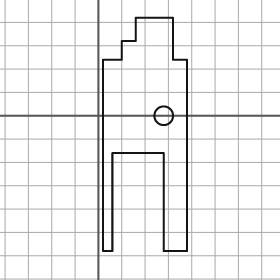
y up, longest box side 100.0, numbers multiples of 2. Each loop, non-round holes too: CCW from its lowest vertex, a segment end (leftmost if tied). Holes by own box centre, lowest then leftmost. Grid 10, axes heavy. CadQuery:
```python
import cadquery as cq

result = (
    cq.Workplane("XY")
    .moveTo(2.0, -58.0)
    .lineTo(6.0, -58.0)
    .lineTo(6.0, -16.0)
    .lineTo(28.0, -16.0)
    .lineTo(28.0, -58.0)
    .lineTo(38.0, -58.0)
    .lineTo(38.0, 24.0)
    .lineTo(32.0, 24.0)
    .lineTo(32.0, 42.0)
    .lineTo(16.0, 42.0)
    .lineTo(16.0, 32.0)
    .lineTo(10.0, 32.0)
    .lineTo(10.0, 24.0)
    .lineTo(2.0, 24.0)
    .close()
    .moveTo(28.0, 0.0)
    .circle(4.0)
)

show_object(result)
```